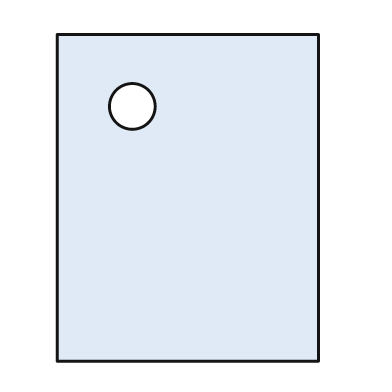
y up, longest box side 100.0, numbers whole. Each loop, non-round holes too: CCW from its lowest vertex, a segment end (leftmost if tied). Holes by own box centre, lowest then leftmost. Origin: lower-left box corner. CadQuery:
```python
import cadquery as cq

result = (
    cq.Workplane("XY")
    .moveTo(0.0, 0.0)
    .lineTo(80.0, 0.0)
    .lineTo(80.0, 100.0)
    .lineTo(0.0, 100.0)
    .close()
    .moveTo(23.0, 78.0)
    .circle(7.0)
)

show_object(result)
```